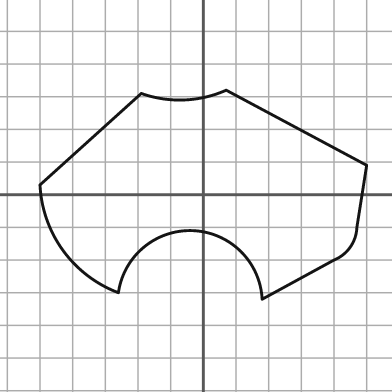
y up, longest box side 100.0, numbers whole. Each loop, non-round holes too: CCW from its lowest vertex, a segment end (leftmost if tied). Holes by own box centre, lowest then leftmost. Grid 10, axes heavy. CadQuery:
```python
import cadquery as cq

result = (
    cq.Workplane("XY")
    .moveTo(18.0, -32.0)
    .lineTo(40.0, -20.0)
    .threePointArc((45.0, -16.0), (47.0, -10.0))
    .lineTo(50.0, 9.0)
    .lineTo(7.0, 32.0)
    .threePointArc((-6.0, 29.0), (-19.0, 31.0))
    .lineTo(-50.0, 3.0)
    .threePointArc((-43.0, -17.0), (-26.0, -30.0))
    .threePointArc((-3.0, -11.0), (18.0, -32.0))
    .close()
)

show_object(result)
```